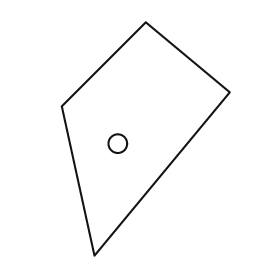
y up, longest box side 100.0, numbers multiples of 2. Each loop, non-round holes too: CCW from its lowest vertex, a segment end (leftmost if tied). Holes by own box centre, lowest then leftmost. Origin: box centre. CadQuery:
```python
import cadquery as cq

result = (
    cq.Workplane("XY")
    .moveTo(-22.0, -50.0)
    .lineTo(36.0, 20.0)
    .lineTo(0.0, 50.0)
    .lineTo(-36.0, 14.0)
    .close()
    .moveTo(-12.0, -2.0)
    .circle(4.0)
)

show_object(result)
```